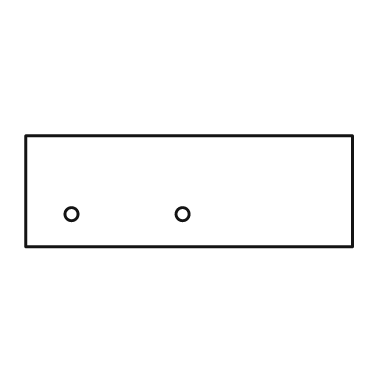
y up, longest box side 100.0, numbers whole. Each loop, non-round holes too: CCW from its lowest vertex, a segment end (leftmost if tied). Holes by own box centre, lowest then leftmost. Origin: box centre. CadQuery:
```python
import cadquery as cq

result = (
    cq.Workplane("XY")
    .moveTo(-50.0, -17.0)
    .lineTo(50.0, -17.0)
    .lineTo(50.0, 17.0)
    .lineTo(-50.0, 17.0)
    .close()
    .moveTo(-36.0, -7.0)
    .circle(2.0)
    .moveTo(-2.0, -7.0)
    .circle(2.0)
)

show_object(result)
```